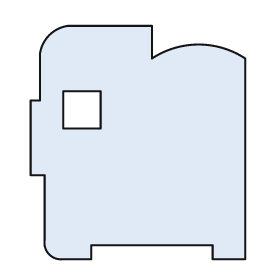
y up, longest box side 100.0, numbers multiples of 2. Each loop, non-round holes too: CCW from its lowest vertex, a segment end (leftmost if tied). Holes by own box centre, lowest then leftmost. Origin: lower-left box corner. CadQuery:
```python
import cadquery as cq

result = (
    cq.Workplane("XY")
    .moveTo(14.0, 0.0)
    .lineTo(26.0, 0.0)
    .lineTo(26.0, 6.0)
    .lineTo(78.0, 6.0)
    .lineTo(78.0, 0.0)
    .lineTo(92.0, 0.0)
    .lineTo(92.0, 86.0)
    .threePointArc((72.0, 92.0), (52.0, 86.0))
    .lineTo(52.0, 100.0)
    .lineTo(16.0, 100.0)
    .threePointArc((8.0, 96.0), (4.0, 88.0))
    .lineTo(4.0, 68.0)
    .lineTo(0.0, 68.0)
    .lineTo(0.0, 36.0)
    .lineTo(6.0, 36.0)
    .lineTo(6.0, 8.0)
    .threePointArc((8.0, 2.0), (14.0, 0.0))
    .close()
    .moveTo(14.0, 56.0)
    .lineTo(30.0, 56.0)
    .lineTo(30.0, 72.0)
    .lineTo(14.0, 72.0)
    .close()
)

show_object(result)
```